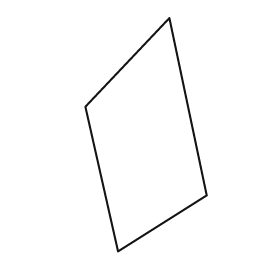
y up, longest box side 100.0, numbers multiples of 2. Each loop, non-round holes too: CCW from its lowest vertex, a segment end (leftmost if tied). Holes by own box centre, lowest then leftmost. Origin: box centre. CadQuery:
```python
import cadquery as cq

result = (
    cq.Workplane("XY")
    .moveTo(-12.0, -50.0)
    .lineTo(26.0, -26.0)
    .lineTo(10.0, 50.0)
    .lineTo(-26.0, 12.0)
    .close()
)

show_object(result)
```